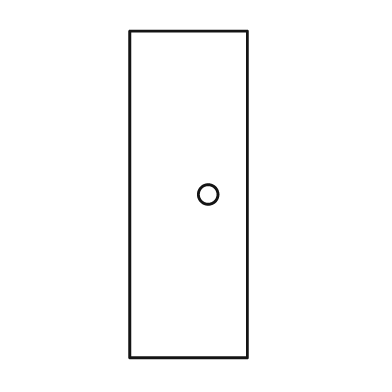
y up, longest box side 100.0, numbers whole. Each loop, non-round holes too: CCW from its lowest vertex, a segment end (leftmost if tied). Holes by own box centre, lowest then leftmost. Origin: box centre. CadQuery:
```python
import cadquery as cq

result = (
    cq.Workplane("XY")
    .moveTo(-18.0, -50.0)
    .lineTo(18.0, -50.0)
    .lineTo(18.0, 50.0)
    .lineTo(-18.0, 50.0)
    .close()
    .moveTo(6.0, 0.0)
    .circle(3.0)
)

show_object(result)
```